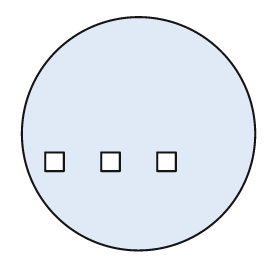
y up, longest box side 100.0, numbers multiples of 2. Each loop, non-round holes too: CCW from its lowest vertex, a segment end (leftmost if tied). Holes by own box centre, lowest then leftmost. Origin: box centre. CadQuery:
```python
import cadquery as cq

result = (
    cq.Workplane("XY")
    .moveTo(0.0, 0.0)
    .circle(50.0)
    .moveTo(-40.0, -16.0)
    .lineTo(-32.0, -16.0)
    .lineTo(-32.0, -8.0)
    .lineTo(-40.0, -8.0)
    .close()
    .moveTo(-16.0, -16.0)
    .lineTo(-8.0, -16.0)
    .lineTo(-8.0, -8.0)
    .lineTo(-16.0, -8.0)
    .close()
    .moveTo(8.0, -16.0)
    .lineTo(16.0, -16.0)
    .lineTo(16.0, -8.0)
    .lineTo(8.0, -8.0)
    .close()
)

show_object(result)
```